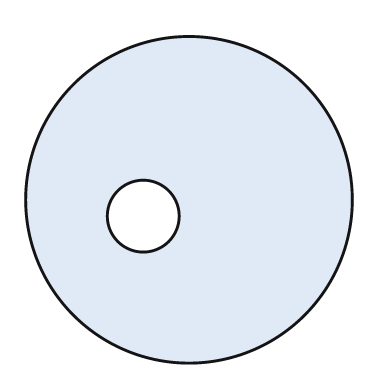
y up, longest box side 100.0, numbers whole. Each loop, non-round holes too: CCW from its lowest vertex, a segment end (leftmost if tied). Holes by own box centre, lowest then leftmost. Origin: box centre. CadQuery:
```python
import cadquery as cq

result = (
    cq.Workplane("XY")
    .moveTo(0.0, 0.0)
    .circle(50.0)
    .moveTo(-14.0, -5.0)
    .circle(11.0)
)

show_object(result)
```